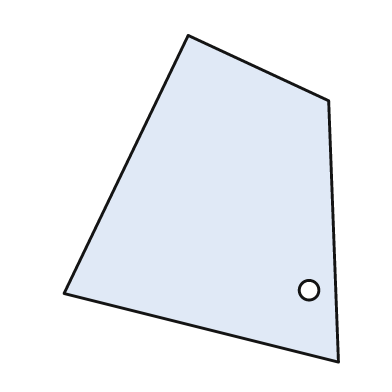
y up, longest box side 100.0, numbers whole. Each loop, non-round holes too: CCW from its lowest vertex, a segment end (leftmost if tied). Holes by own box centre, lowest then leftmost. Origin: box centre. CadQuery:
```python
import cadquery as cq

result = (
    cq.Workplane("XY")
    .moveTo(42.0, -50.0)
    .lineTo(39.0, 30.0)
    .lineTo(-4.0, 50.0)
    .lineTo(-42.0, -29.0)
    .close()
    .moveTo(33.0, -28.0)
    .circle(3.0)
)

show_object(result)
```